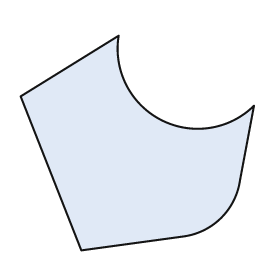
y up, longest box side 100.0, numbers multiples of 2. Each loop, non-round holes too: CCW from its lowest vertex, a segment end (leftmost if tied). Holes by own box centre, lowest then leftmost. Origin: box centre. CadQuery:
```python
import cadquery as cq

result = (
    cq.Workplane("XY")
    .moveTo(-24.0, -46.0)
    .lineTo(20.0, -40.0)
    .threePointArc((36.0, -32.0), (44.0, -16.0))
    .lineTo(50.0, 16.0)
    .threePointArc((10.0, 10.0), (-8.0, 46.0))
    .lineTo(-50.0, 20.0)
    .close()
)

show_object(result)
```